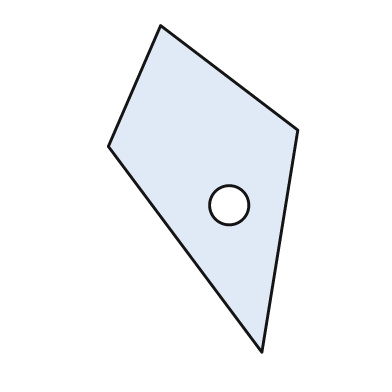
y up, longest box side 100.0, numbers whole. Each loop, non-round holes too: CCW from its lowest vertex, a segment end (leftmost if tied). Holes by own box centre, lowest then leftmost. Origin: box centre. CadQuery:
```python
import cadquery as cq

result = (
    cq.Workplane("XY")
    .moveTo(18.0, -50.0)
    .lineTo(29.0, 18.0)
    .lineTo(-13.0, 50.0)
    .lineTo(-29.0, 13.0)
    .close()
    .moveTo(8.0, -5.0)
    .circle(6.0)
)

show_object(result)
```